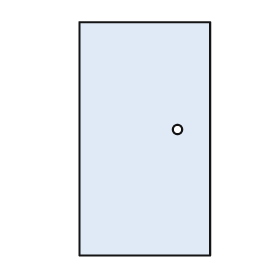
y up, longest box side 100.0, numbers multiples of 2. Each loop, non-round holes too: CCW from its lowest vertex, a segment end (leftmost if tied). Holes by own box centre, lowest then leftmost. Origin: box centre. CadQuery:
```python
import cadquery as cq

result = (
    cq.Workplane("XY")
    .moveTo(-28.0, -50.0)
    .lineTo(28.0, -50.0)
    .lineTo(28.0, 50.0)
    .lineTo(-28.0, 50.0)
    .close()
    .moveTo(14.0, 4.0)
    .circle(2.0)
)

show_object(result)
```